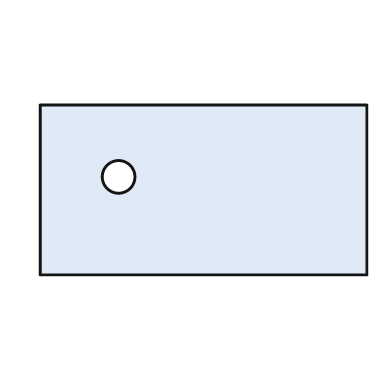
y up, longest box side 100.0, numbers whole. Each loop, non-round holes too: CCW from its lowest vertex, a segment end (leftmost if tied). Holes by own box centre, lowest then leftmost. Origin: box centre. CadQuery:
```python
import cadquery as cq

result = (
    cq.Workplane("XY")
    .moveTo(-50.0, -26.0)
    .lineTo(50.0, -26.0)
    .lineTo(50.0, 26.0)
    .lineTo(-50.0, 26.0)
    .close()
    .moveTo(-26.0, 4.0)
    .circle(5.0)
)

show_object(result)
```